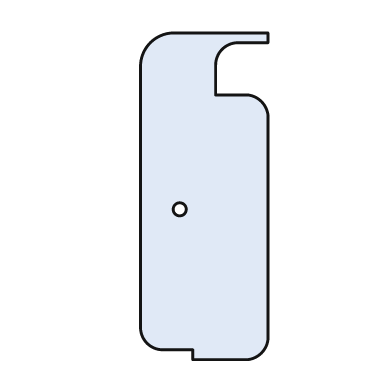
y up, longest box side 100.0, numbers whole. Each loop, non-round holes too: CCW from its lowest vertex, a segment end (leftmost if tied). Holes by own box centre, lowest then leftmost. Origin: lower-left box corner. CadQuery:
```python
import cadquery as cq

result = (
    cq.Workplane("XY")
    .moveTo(16.0, 0.0)
    .lineTo(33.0, 0.0)
    .threePointArc((37.0, 2.0), (39.0, 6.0))
    .lineTo(39.0, 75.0)
    .threePointArc((37.0, 79.0), (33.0, 81.0))
    .lineTo(23.0, 81.0)
    .lineTo(23.0, 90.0)
    .threePointArc((25.0, 95.0), (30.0, 97.0))
    .lineTo(39.0, 97.0)
    .lineTo(39.0, 100.0)
    .lineTo(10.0, 100.0)
    .threePointArc((3.0, 97.0), (0.0, 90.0))
    .lineTo(0.0, 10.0)
    .threePointArc((2.0, 5.0), (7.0, 3.0))
    .lineTo(16.0, 3.0)
    .close()
    .moveTo(12.0, 46.0)
    .circle(2.0)
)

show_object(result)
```